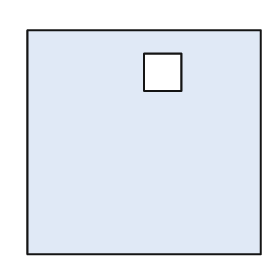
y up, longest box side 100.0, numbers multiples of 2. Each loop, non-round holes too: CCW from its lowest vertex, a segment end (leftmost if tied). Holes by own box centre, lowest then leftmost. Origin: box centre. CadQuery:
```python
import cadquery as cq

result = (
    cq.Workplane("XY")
    .moveTo(-50.0, -48.0)
    .lineTo(50.0, -48.0)
    .lineTo(50.0, 48.0)
    .lineTo(-50.0, 48.0)
    .close()
    .moveTo(0.0, 22.0)
    .lineTo(16.0, 22.0)
    .lineTo(16.0, 38.0)
    .lineTo(0.0, 38.0)
    .close()
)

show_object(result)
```